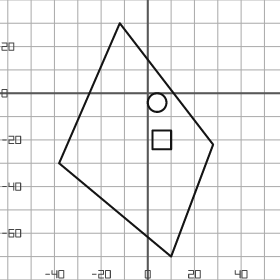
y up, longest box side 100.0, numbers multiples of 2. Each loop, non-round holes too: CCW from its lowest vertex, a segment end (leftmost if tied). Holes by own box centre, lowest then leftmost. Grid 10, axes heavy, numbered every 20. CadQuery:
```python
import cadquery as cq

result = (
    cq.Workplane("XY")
    .moveTo(10.0, -70.0)
    .lineTo(28.0, -22.0)
    .lineTo(-12.0, 30.0)
    .lineTo(-38.0, -30.0)
    .close()
    .moveTo(2.0, -24.0)
    .lineTo(10.0, -24.0)
    .lineTo(10.0, -16.0)
    .lineTo(2.0, -16.0)
    .close()
    .moveTo(4.0, -4.0)
    .circle(4.0)
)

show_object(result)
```